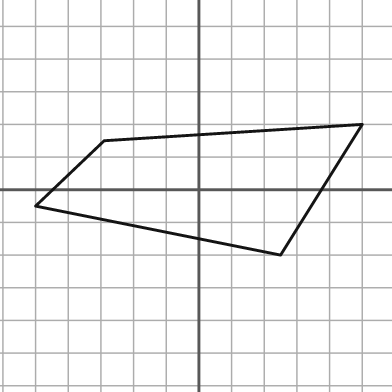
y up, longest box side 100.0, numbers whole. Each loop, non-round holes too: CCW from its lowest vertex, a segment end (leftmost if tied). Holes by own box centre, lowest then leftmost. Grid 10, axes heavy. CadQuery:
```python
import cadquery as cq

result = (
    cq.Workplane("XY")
    .moveTo(25.0, -20.0)
    .lineTo(50.0, 20.0)
    .lineTo(-29.0, 15.0)
    .lineTo(-50.0, -5.0)
    .close()
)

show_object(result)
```